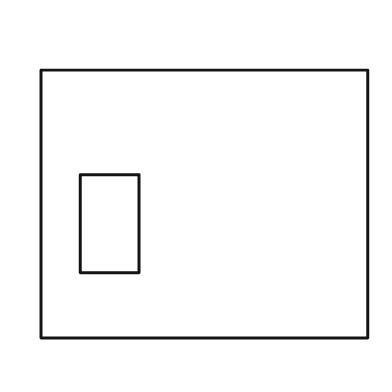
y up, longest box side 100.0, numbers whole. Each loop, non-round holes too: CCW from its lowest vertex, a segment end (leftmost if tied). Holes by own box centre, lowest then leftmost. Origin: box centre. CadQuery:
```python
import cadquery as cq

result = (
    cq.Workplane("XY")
    .moveTo(-50.0, -41.0)
    .lineTo(50.0, -41.0)
    .lineTo(50.0, 41.0)
    .lineTo(-50.0, 41.0)
    .close()
    .moveTo(-38.0, -21.0)
    .lineTo(-20.0, -21.0)
    .lineTo(-20.0, 9.0)
    .lineTo(-38.0, 9.0)
    .close()
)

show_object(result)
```